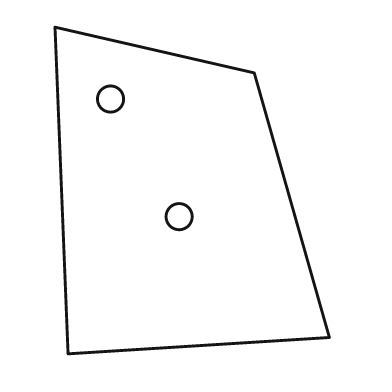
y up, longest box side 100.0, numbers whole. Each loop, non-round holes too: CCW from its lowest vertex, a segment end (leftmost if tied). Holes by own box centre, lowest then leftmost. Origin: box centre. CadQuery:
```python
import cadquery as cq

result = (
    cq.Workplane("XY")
    .moveTo(-38.0, -50.0)
    .lineTo(42.0, -45.0)
    .lineTo(19.0, 36.0)
    .lineTo(-42.0, 50.0)
    .close()
    .moveTo(-4.0, -8.0)
    .circle(4.0)
    .moveTo(-25.0, 28.0)
    .circle(4.0)
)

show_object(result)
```